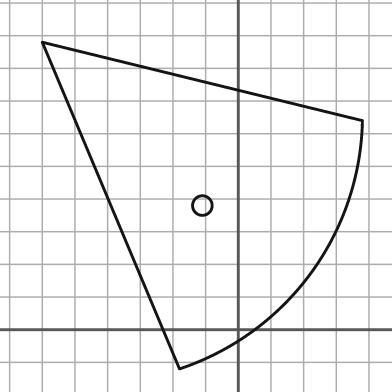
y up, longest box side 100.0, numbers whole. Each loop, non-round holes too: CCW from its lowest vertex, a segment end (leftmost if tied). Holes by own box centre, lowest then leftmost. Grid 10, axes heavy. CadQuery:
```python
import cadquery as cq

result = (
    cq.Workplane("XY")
    .moveTo(-18.0, -12.0)
    .threePointArc((22.0, 17.0), (38.0, 64.0))
    .lineTo(-60.0, 88.0)
    .close()
    .moveTo(-11.0, 38.0)
    .circle(3.0)
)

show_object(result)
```